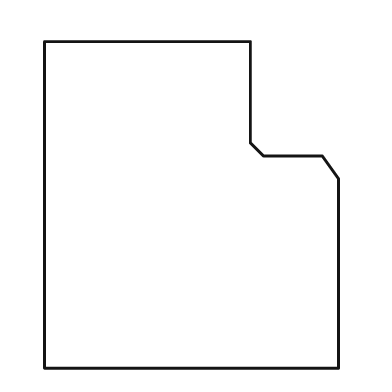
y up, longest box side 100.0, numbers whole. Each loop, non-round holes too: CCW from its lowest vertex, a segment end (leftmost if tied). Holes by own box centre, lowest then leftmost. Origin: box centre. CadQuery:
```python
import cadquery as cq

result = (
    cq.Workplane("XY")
    .moveTo(-45.0, -50.0)
    .lineTo(45.0, -50.0)
    .lineTo(45.0, 8.0)
    .lineTo(40.0, 15.0)
    .lineTo(22.0, 15.0)
    .lineTo(18.0, 19.0)
    .lineTo(18.0, 50.0)
    .lineTo(-45.0, 50.0)
    .close()
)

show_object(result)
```